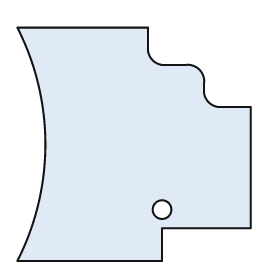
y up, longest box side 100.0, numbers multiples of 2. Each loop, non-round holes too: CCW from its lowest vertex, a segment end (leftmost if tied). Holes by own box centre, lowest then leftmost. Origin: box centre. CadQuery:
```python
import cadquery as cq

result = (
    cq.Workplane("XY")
    .moveTo(-50.0, -50.0)
    .lineTo(12.0, -50.0)
    .lineTo(12.0, -36.0)
    .lineTo(50.0, -36.0)
    .lineTo(50.0, 16.0)
    .lineTo(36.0, 16.0)
    .threePointArc((32.0, 18.0), (30.0, 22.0))
    .lineTo(30.0, 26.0)
    .threePointArc((28.0, 32.0), (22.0, 34.0))
    .lineTo(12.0, 34.0)
    .threePointArc((8.0, 36.0), (6.0, 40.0))
    .lineTo(6.0, 50.0)
    .lineTo(-50.0, 50.0)
    .threePointArc((-38.0, 0.0), (-50.0, -50.0))
    .close()
    .moveTo(12.0, -28.0)
    .circle(4.0)
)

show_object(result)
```